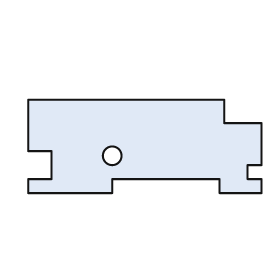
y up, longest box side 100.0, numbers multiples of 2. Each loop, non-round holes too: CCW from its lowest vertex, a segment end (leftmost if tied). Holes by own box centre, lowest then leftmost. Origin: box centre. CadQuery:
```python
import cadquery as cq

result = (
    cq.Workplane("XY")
    .moveTo(-50.0, -20.0)
    .lineTo(-14.0, -20.0)
    .lineTo(-14.0, -14.0)
    .lineTo(32.0, -14.0)
    .lineTo(32.0, -20.0)
    .lineTo(50.0, -20.0)
    .lineTo(50.0, -14.0)
    .lineTo(44.0, -14.0)
    .lineTo(44.0, -8.0)
    .lineTo(50.0, -8.0)
    .lineTo(50.0, 10.0)
    .lineTo(34.0, 10.0)
    .lineTo(34.0, 20.0)
    .lineTo(-50.0, 20.0)
    .lineTo(-50.0, -2.0)
    .lineTo(-40.0, -2.0)
    .lineTo(-40.0, -14.0)
    .lineTo(-50.0, -14.0)
    .close()
    .moveTo(-14.0, -4.0)
    .circle(4.0)
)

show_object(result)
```